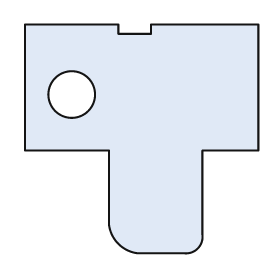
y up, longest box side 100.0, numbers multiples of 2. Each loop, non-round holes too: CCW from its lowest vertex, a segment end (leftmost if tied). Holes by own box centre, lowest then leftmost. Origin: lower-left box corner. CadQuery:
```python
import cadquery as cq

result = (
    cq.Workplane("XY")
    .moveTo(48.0, 0.0)
    .lineTo(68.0, 0.0)
    .threePointArc((74.0, 2.0), (76.0, 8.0))
    .lineTo(76.0, 44.0)
    .lineTo(100.0, 44.0)
    .lineTo(100.0, 98.0)
    .lineTo(54.0, 98.0)
    .lineTo(54.0, 94.0)
    .lineTo(40.0, 94.0)
    .lineTo(40.0, 98.0)
    .lineTo(0.0, 98.0)
    .lineTo(0.0, 44.0)
    .lineTo(36.0, 44.0)
    .lineTo(36.0, 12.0)
    .threePointArc((40.0, 4.0), (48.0, 0.0))
    .close()
    .moveTo(20.0, 68.0)
    .circle(10.0)
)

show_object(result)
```